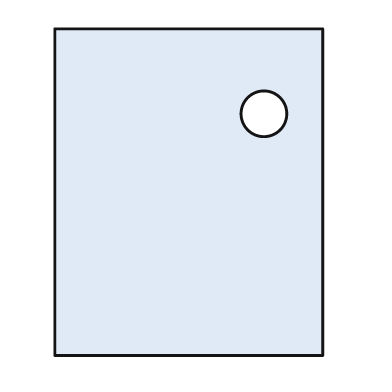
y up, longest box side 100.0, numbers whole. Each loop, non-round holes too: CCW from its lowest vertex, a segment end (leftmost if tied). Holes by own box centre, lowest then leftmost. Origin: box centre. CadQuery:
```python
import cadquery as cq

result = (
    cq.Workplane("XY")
    .moveTo(-41.0, -50.0)
    .lineTo(41.0, -50.0)
    .lineTo(41.0, 50.0)
    .lineTo(-41.0, 50.0)
    .close()
    .moveTo(23.0, 24.0)
    .circle(7.0)
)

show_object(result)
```